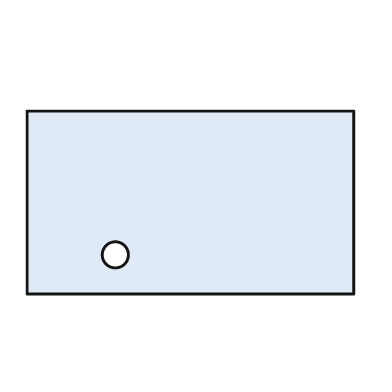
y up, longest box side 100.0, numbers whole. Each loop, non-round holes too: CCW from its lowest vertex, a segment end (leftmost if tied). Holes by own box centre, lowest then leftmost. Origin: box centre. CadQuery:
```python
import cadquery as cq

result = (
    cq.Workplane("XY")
    .moveTo(-50.0, -28.0)
    .lineTo(50.0, -28.0)
    .lineTo(50.0, 28.0)
    .lineTo(-50.0, 28.0)
    .close()
    .moveTo(-23.0, -16.0)
    .circle(4.0)
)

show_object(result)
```